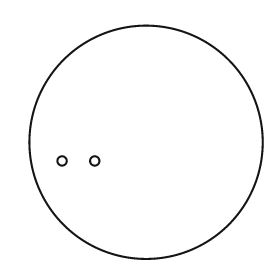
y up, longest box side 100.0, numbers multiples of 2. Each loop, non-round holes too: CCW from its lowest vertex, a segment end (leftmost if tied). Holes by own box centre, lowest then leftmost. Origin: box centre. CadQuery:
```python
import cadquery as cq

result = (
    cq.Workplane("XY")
    .moveTo(0.0, 0.0)
    .circle(50.0)
    .moveTo(-36.0, -8.0)
    .circle(2.0)
    .moveTo(-22.0, -8.0)
    .circle(2.0)
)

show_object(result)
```